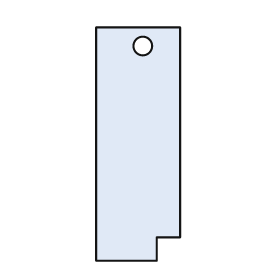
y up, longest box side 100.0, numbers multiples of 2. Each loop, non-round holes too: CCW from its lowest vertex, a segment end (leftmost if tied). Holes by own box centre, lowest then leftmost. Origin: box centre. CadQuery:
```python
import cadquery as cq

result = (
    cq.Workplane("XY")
    .moveTo(-18.0, -50.0)
    .lineTo(8.0, -50.0)
    .lineTo(8.0, -40.0)
    .lineTo(18.0, -40.0)
    .lineTo(18.0, 50.0)
    .lineTo(-18.0, 50.0)
    .close()
    .moveTo(2.0, 42.0)
    .circle(4.0)
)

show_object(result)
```